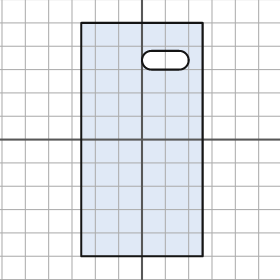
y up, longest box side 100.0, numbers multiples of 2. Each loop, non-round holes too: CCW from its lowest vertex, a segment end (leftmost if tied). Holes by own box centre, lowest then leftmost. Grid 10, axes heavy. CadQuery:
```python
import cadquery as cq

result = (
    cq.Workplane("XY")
    .moveTo(-26.0, -50.0)
    .lineTo(26.0, -50.0)
    .lineTo(26.0, 50.0)
    .lineTo(-26.0, 50.0)
    .close()
    .moveTo(4.0, 30.0)
    .lineTo(16.0, 30.0)
    .threePointArc((20.0, 34.0), (16.0, 38.0))
    .lineTo(4.0, 38.0)
    .threePointArc((0.0, 34.0), (4.0, 30.0))
    .close()
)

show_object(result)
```